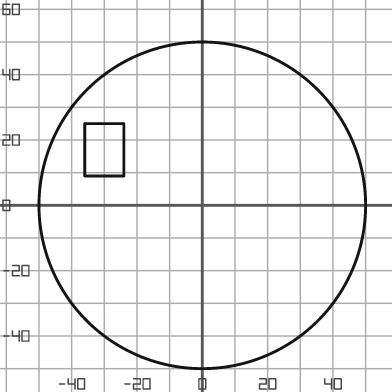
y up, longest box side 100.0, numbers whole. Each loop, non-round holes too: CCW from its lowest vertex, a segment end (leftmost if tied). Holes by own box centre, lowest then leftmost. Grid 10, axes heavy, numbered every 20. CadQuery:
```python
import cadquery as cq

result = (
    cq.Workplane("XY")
    .moveTo(0.0, 0.0)
    .circle(50.0)
    .moveTo(-36.0, 9.0)
    .lineTo(-24.0, 9.0)
    .lineTo(-24.0, 25.0)
    .lineTo(-36.0, 25.0)
    .close()
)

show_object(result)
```